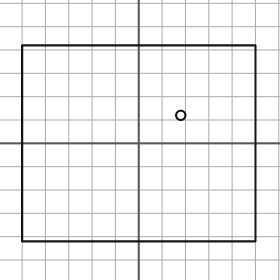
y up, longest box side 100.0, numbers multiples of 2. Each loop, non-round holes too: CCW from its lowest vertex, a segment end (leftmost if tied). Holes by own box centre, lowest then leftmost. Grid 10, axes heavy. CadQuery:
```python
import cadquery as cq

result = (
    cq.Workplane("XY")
    .moveTo(-50.0, -42.0)
    .lineTo(50.0, -42.0)
    .lineTo(50.0, 42.0)
    .lineTo(-50.0, 42.0)
    .close()
    .moveTo(18.0, 12.0)
    .circle(2.0)
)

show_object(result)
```